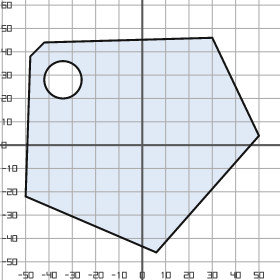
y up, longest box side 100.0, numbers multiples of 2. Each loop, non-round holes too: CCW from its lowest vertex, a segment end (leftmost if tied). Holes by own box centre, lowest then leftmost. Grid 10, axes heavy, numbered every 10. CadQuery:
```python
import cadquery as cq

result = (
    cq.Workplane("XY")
    .moveTo(6.0, -46.0)
    .lineTo(50.0, 4.0)
    .lineTo(30.0, 46.0)
    .lineTo(-42.0, 44.0)
    .lineTo(-48.0, 38.0)
    .lineTo(-50.0, -22.0)
    .close()
    .moveTo(-34.0, 28.0)
    .circle(8.0)
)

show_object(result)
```